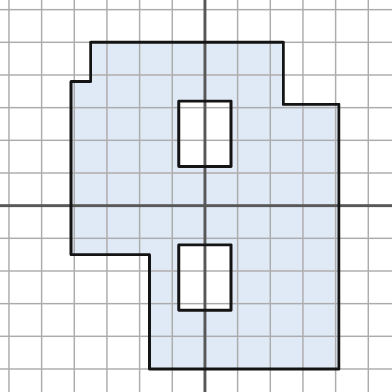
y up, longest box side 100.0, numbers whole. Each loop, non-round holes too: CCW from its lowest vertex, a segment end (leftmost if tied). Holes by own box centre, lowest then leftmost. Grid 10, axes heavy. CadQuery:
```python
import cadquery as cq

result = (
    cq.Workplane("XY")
    .moveTo(-17.0, -50.0)
    .lineTo(41.0, -50.0)
    .lineTo(41.0, 31.0)
    .lineTo(24.0, 31.0)
    .lineTo(24.0, 50.0)
    .lineTo(-35.0, 50.0)
    .lineTo(-35.0, 38.0)
    .lineTo(-41.0, 38.0)
    .lineTo(-41.0, -15.0)
    .lineTo(-17.0, -15.0)
    .close()
    .moveTo(-8.0, -32.0)
    .lineTo(8.0, -32.0)
    .lineTo(8.0, -12.0)
    .lineTo(-8.0, -12.0)
    .close()
    .moveTo(-8.0, 12.0)
    .lineTo(8.0, 12.0)
    .lineTo(8.0, 32.0)
    .lineTo(-8.0, 32.0)
    .close()
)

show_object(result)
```